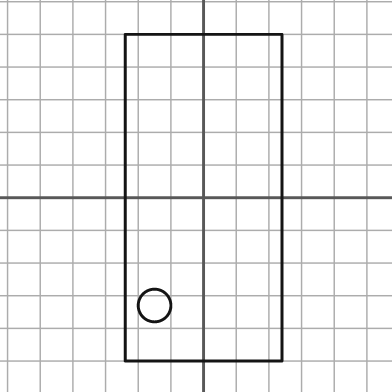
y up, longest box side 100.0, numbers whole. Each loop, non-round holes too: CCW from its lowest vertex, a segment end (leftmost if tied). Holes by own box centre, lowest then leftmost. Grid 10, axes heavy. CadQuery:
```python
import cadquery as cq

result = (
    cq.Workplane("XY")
    .moveTo(-24.0, -50.0)
    .lineTo(24.0, -50.0)
    .lineTo(24.0, 50.0)
    .lineTo(-24.0, 50.0)
    .close()
    .moveTo(-15.0, -33.0)
    .circle(5.0)
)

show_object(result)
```